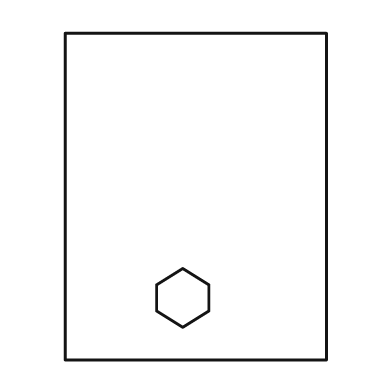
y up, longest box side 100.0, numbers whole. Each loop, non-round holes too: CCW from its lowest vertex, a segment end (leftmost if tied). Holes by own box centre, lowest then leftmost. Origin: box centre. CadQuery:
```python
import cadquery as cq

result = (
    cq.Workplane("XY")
    .moveTo(-40.0, -50.0)
    .lineTo(40.0, -50.0)
    .lineTo(40.0, 50.0)
    .lineTo(-40.0, 50.0)
    .close()
    .moveTo(-4.0, -40.0)
    .lineTo(4.0, -35.0)
    .lineTo(4.0, -27.0)
    .lineTo(-4.0, -22.0)
    .lineTo(-12.0, -27.0)
    .lineTo(-12.0, -35.0)
    .close()
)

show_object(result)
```